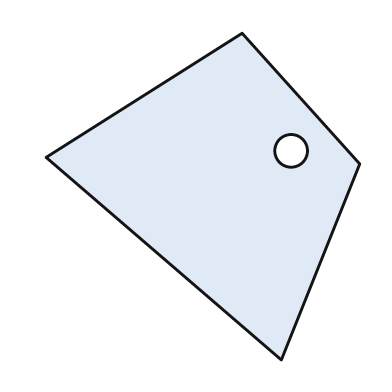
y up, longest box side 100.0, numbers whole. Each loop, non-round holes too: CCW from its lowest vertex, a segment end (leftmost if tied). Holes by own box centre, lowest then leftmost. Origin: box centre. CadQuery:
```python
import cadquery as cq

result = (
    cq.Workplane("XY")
    .moveTo(24.0, -50.0)
    .lineTo(48.0, 10.0)
    .lineTo(12.0, 50.0)
    .lineTo(-48.0, 12.0)
    .close()
    .moveTo(27.0, 14.0)
    .circle(5.0)
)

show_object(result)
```